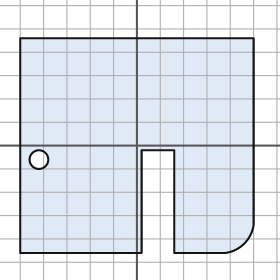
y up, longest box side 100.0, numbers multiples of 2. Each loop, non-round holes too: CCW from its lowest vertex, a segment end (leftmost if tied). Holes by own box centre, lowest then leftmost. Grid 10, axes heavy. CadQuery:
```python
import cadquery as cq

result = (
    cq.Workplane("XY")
    .moveTo(-50.0, -46.0)
    .lineTo(2.0, -46.0)
    .lineTo(2.0, -2.0)
    .lineTo(16.0, -2.0)
    .lineTo(16.0, -46.0)
    .lineTo(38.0, -46.0)
    .threePointArc((46.0, -42.0), (50.0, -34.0))
    .lineTo(50.0, 46.0)
    .lineTo(-50.0, 46.0)
    .close()
    .moveTo(-42.0, -6.0)
    .circle(4.0)
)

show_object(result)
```